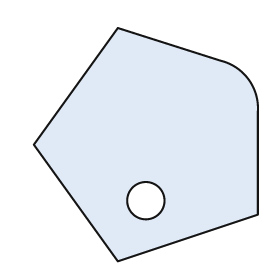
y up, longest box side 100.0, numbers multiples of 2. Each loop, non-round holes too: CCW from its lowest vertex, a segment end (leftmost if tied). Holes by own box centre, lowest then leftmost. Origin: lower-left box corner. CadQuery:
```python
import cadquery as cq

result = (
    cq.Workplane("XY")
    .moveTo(36.0, 0.0)
    .lineTo(96.0, 20.0)
    .lineTo(96.0, 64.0)
    .threePointArc((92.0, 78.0), (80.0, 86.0))
    .lineTo(36.0, 100.0)
    .lineTo(0.0, 50.0)
    .close()
    .moveTo(48.0, 26.0)
    .circle(8.0)
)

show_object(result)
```